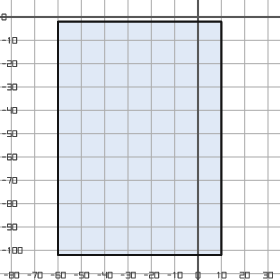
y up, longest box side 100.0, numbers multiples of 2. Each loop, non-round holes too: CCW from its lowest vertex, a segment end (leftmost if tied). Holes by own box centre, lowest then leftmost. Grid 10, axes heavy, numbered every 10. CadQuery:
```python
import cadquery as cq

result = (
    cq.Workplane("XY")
    .moveTo(-60.0, -102.0)
    .lineTo(10.0, -102.0)
    .lineTo(10.0, -2.0)
    .lineTo(-60.0, -2.0)
    .close()
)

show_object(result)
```